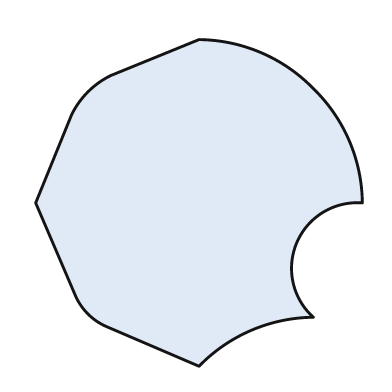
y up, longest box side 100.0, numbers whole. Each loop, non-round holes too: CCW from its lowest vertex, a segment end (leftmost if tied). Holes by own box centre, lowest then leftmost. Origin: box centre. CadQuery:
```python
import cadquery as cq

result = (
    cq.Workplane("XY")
    .moveTo(0.0, -50.0)
    .threePointArc((16.0, -39.0), (35.0, -35.0))
    .threePointArc((30.0, -12.0), (50.0, 0.0))
    .threePointArc((46.0, 19.0), (35.0, 35.0))
    .threePointArc((19.0, 46.0), (0.0, 50.0))
    .lineTo(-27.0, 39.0)
    .threePointArc((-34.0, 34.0), (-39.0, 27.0))
    .lineTo(-50.0, 0.0)
    .lineTo(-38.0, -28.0)
    .threePointArc((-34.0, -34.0), (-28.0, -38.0))
    .close()
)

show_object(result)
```